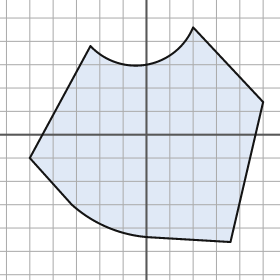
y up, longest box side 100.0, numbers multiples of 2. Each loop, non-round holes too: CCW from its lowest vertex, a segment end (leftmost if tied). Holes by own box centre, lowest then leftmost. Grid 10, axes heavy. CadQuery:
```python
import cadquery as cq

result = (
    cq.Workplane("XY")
    .moveTo(36.0, -46.0)
    .lineTo(50.0, 14.0)
    .lineTo(20.0, 46.0)
    .threePointArc((0.0, 30.0), (-24.0, 38.0))
    .lineTo(-50.0, -10.0)
    .lineTo(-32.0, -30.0)
    .threePointArc((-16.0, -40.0), (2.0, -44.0))
    .close()
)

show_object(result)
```